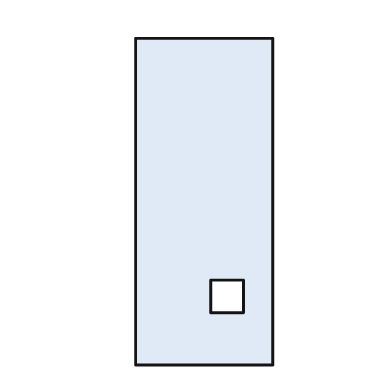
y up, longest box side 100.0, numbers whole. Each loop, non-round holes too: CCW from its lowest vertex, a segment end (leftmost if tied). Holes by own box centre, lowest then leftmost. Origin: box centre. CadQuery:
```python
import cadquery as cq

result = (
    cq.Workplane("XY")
    .moveTo(-21.0, -50.0)
    .lineTo(21.0, -50.0)
    .lineTo(21.0, 50.0)
    .lineTo(-21.0, 50.0)
    .close()
    .moveTo(2.0, -34.0)
    .lineTo(12.0, -34.0)
    .lineTo(12.0, -24.0)
    .lineTo(2.0, -24.0)
    .close()
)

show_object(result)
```